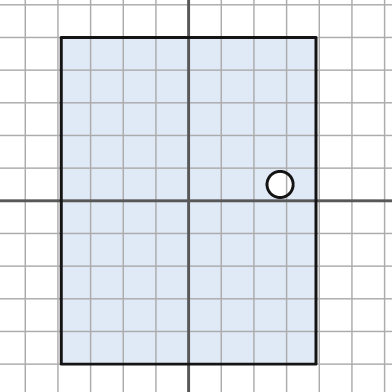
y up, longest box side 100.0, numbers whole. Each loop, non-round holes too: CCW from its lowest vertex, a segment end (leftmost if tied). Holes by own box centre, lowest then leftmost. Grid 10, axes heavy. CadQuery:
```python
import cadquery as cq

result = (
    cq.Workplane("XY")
    .moveTo(-39.0, -50.0)
    .lineTo(39.0, -50.0)
    .lineTo(39.0, 50.0)
    .lineTo(-39.0, 50.0)
    .close()
    .moveTo(28.0, 5.0)
    .circle(4.0)
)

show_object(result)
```